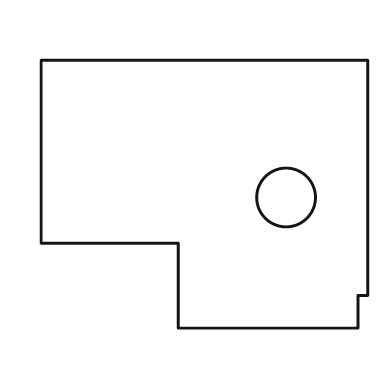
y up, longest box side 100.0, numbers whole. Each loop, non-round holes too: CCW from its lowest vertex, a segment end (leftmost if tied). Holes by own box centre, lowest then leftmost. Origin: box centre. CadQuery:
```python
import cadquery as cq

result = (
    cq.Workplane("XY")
    .moveTo(-8.0, -41.0)
    .lineTo(47.0, -41.0)
    .lineTo(47.0, -31.0)
    .lineTo(50.0, -31.0)
    .lineTo(50.0, 41.0)
    .lineTo(-50.0, 41.0)
    .lineTo(-50.0, -15.0)
    .lineTo(-8.0, -15.0)
    .close()
    .moveTo(25.0, -1.0)
    .circle(9.0)
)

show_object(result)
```